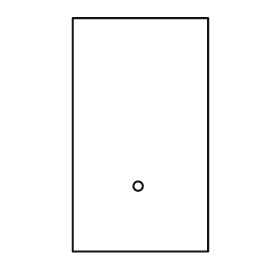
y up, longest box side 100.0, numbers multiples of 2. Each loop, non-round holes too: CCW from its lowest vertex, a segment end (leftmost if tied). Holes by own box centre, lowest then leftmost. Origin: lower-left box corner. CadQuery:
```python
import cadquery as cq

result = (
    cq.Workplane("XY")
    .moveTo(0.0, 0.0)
    .lineTo(58.0, 0.0)
    .lineTo(58.0, 100.0)
    .lineTo(0.0, 100.0)
    .close()
    .moveTo(28.0, 28.0)
    .circle(2.0)
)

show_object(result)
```